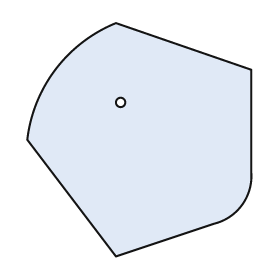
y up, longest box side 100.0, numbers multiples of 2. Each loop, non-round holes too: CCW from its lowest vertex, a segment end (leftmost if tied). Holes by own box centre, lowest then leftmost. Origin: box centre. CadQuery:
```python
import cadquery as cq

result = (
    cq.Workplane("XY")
    .moveTo(-10.0, -50.0)
    .lineTo(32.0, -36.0)
    .threePointArc((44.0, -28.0), (48.0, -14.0))
    .lineTo(48.0, 30.0)
    .lineTo(-10.0, 50.0)
    .threePointArc((-36.0, 30.0), (-48.0, 0.0))
    .close()
    .moveTo(-8.0, 16.0)
    .circle(2.0)
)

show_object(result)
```